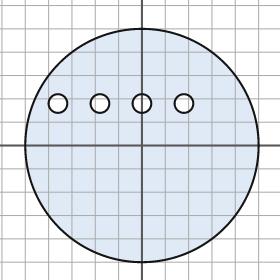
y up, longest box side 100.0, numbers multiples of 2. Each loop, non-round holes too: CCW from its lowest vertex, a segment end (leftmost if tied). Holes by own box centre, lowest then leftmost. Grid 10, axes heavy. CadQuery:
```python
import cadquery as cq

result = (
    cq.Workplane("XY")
    .moveTo(0.0, 0.0)
    .circle(50.0)
    .moveTo(-36.0, 18.0)
    .circle(4.0)
    .moveTo(-18.0, 18.0)
    .circle(4.0)
    .moveTo(0.0, 18.0)
    .circle(4.0)
    .moveTo(18.0, 18.0)
    .circle(4.0)
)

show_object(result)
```